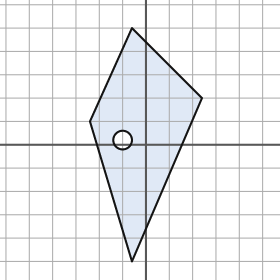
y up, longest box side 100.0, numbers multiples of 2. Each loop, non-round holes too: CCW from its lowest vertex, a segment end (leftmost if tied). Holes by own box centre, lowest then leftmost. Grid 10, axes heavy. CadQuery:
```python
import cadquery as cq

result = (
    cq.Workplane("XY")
    .moveTo(-6.0, -50.0)
    .lineTo(24.0, 20.0)
    .lineTo(-6.0, 50.0)
    .lineTo(-24.0, 10.0)
    .close()
    .moveTo(-10.0, 2.0)
    .circle(4.0)
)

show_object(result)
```